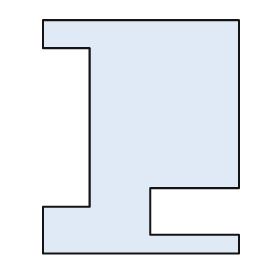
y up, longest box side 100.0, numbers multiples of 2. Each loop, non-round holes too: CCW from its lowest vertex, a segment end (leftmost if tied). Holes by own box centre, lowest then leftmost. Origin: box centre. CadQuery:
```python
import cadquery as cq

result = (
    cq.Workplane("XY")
    .moveTo(-42.0, -50.0)
    .lineTo(42.0, -50.0)
    .lineTo(42.0, -42.0)
    .lineTo(4.0, -42.0)
    .lineTo(4.0, -22.0)
    .lineTo(42.0, -22.0)
    .lineTo(42.0, 50.0)
    .lineTo(-42.0, 50.0)
    .lineTo(-42.0, 38.0)
    .lineTo(-22.0, 38.0)
    .lineTo(-22.0, -30.0)
    .lineTo(-42.0, -30.0)
    .close()
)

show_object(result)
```